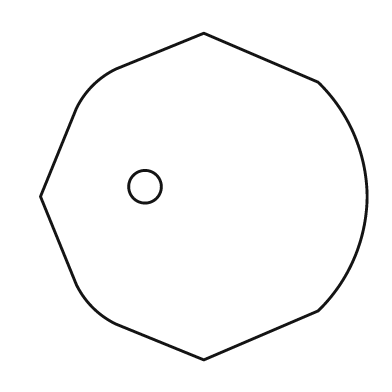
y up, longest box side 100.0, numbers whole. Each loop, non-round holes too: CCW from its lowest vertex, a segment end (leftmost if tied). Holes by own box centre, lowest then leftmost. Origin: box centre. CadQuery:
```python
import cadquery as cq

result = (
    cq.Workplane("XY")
    .moveTo(0.0, -50.0)
    .lineTo(35.0, -35.0)
    .threePointArc((46.0, -19.0), (50.0, 0.0))
    .threePointArc((46.0, 19.0), (35.0, 35.0))
    .lineTo(0.0, 50.0)
    .lineTo(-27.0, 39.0)
    .threePointArc((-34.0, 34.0), (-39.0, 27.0))
    .lineTo(-50.0, 0.0)
    .lineTo(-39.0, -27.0)
    .threePointArc((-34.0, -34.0), (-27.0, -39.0))
    .close()
    .moveTo(-18.0, 3.0)
    .circle(5.0)
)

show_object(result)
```